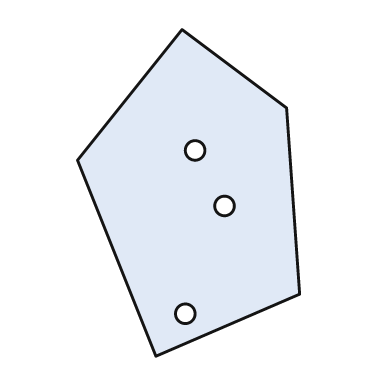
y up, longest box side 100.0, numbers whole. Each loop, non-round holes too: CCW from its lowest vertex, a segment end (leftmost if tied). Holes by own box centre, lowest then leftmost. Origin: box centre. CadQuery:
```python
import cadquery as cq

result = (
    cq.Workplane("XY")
    .moveTo(-10.0, -50.0)
    .lineTo(34.0, -31.0)
    .lineTo(30.0, 26.0)
    .lineTo(-2.0, 50.0)
    .lineTo(-34.0, 10.0)
    .close()
    .moveTo(-1.0, -37.0)
    .circle(3.0)
    .moveTo(11.0, -4.0)
    .circle(3.0)
    .moveTo(2.0, 13.0)
    .circle(3.0)
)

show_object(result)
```